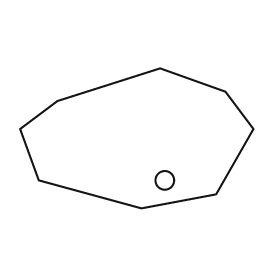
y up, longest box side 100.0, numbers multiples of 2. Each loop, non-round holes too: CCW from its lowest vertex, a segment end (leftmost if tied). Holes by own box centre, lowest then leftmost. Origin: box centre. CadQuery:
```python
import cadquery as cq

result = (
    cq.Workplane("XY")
    .moveTo(2.0, -30.0)
    .lineTo(34.0, -24.0)
    .lineTo(50.0, 4.0)
    .lineTo(38.0, 20.0)
    .lineTo(10.0, 30.0)
    .lineTo(-34.0, 16.0)
    .lineTo(-50.0, 4.0)
    .lineTo(-42.0, -18.0)
    .close()
    .moveTo(12.0, -18.0)
    .circle(4.0)
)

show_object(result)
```